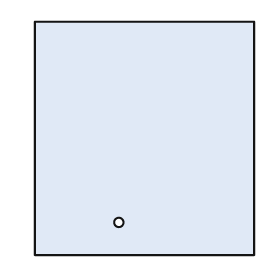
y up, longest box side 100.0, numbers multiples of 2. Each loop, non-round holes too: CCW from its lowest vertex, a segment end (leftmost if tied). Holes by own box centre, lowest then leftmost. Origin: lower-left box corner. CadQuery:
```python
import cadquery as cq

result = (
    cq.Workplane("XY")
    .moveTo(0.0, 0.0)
    .lineTo(94.0, 0.0)
    .lineTo(94.0, 100.0)
    .lineTo(0.0, 100.0)
    .close()
    .moveTo(36.0, 14.0)
    .circle(2.0)
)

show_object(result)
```